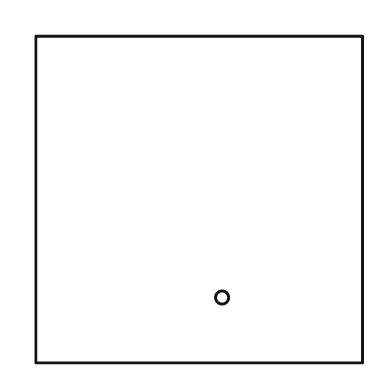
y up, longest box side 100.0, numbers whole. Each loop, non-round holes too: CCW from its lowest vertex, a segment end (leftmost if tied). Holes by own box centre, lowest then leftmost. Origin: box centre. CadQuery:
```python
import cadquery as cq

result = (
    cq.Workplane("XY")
    .moveTo(-50.0, -50.0)
    .lineTo(50.0, -50.0)
    .lineTo(50.0, 50.0)
    .lineTo(-50.0, 50.0)
    .close()
    .moveTo(7.0, -30.0)
    .circle(2.0)
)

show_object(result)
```